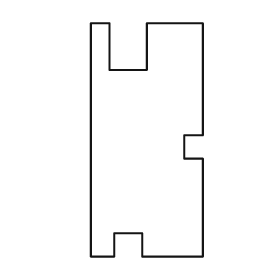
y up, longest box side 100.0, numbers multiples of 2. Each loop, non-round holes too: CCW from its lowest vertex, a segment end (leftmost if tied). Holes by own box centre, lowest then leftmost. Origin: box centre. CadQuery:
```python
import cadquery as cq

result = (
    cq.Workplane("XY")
    .moveTo(-24.0, -50.0)
    .lineTo(-14.0, -50.0)
    .lineTo(-14.0, -40.0)
    .lineTo(-2.0, -40.0)
    .lineTo(-2.0, -50.0)
    .lineTo(24.0, -50.0)
    .lineTo(24.0, -8.0)
    .lineTo(16.0, -8.0)
    .lineTo(16.0, 2.0)
    .lineTo(24.0, 2.0)
    .lineTo(24.0, 50.0)
    .lineTo(0.0, 50.0)
    .lineTo(0.0, 30.0)
    .lineTo(-16.0, 30.0)
    .lineTo(-16.0, 50.0)
    .lineTo(-24.0, 50.0)
    .close()
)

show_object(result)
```